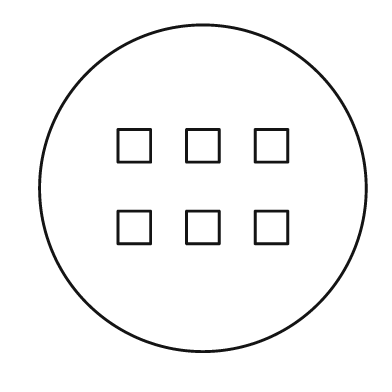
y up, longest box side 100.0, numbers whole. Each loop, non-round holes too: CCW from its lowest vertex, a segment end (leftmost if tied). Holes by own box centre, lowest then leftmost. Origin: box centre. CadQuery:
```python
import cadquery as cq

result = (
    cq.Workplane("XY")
    .moveTo(0.0, 0.0)
    .circle(50.0)
    .moveTo(-26.0, -17.0)
    .lineTo(-16.0, -17.0)
    .lineTo(-16.0, -7.0)
    .lineTo(-26.0, -7.0)
    .close()
    .moveTo(-5.0, -17.0)
    .lineTo(5.0, -17.0)
    .lineTo(5.0, -7.0)
    .lineTo(-5.0, -7.0)
    .close()
    .moveTo(16.0, -17.0)
    .lineTo(26.0, -17.0)
    .lineTo(26.0, -7.0)
    .lineTo(16.0, -7.0)
    .close()
    .moveTo(-26.0, 8.0)
    .lineTo(-16.0, 8.0)
    .lineTo(-16.0, 18.0)
    .lineTo(-26.0, 18.0)
    .close()
    .moveTo(-5.0, 8.0)
    .lineTo(5.0, 8.0)
    .lineTo(5.0, 18.0)
    .lineTo(-5.0, 18.0)
    .close()
    .moveTo(16.0, 8.0)
    .lineTo(26.0, 8.0)
    .lineTo(26.0, 18.0)
    .lineTo(16.0, 18.0)
    .close()
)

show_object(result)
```